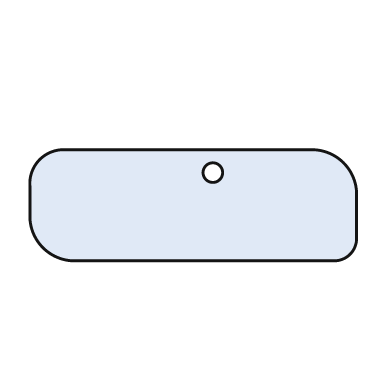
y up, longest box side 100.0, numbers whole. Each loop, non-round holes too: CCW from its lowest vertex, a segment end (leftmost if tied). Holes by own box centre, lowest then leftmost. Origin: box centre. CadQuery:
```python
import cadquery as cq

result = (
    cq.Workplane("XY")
    .moveTo(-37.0, -17.0)
    .lineTo(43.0, -17.0)
    .threePointArc((48.0, -15.0), (50.0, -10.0))
    .lineTo(50.0, 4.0)
    .threePointArc((46.0, 13.0), (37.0, 17.0))
    .lineTo(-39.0, 17.0)
    .threePointArc((-47.0, 14.0), (-50.0, 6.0))
    .lineTo(-50.0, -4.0)
    .threePointArc((-46.0, -13.0), (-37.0, -17.0))
    .close()
    .moveTo(6.0, 10.0)
    .circle(3.0)
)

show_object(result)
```